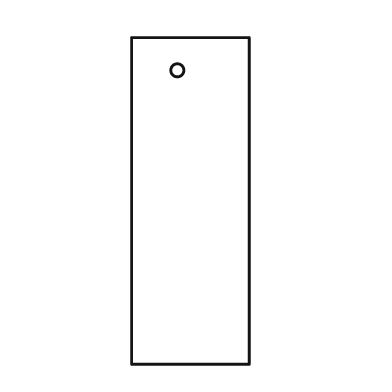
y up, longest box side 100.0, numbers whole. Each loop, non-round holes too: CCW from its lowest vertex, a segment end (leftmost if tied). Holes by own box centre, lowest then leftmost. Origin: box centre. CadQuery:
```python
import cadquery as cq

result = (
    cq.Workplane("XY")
    .moveTo(-18.0, -50.0)
    .lineTo(18.0, -50.0)
    .lineTo(18.0, 50.0)
    .lineTo(-18.0, 50.0)
    .close()
    .moveTo(-4.0, 40.0)
    .circle(2.0)
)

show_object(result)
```